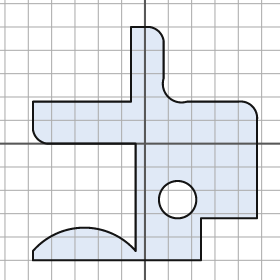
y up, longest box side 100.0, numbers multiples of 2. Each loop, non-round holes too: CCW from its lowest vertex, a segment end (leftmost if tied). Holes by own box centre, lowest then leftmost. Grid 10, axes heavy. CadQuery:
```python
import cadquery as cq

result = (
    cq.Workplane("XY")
    .moveTo(-48.0, -50.0)
    .lineTo(24.0, -50.0)
    .lineTo(24.0, -32.0)
    .lineTo(48.0, -32.0)
    .lineTo(48.0, 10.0)
    .threePointArc((46.0, 16.0), (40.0, 18.0))
    .lineTo(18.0, 18.0)
    .threePointArc((10.0, 20.0), (8.0, 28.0))
    .lineTo(8.0, 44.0)
    .threePointArc((6.0, 48.0), (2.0, 50.0))
    .lineTo(-6.0, 50.0)
    .lineTo(-6.0, 18.0)
    .lineTo(-48.0, 18.0)
    .lineTo(-48.0, 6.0)
    .threePointArc((-46.0, 2.0), (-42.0, 0.0))
    .lineTo(-4.0, 0.0)
    .lineTo(-4.0, -46.0)
    .threePointArc((-26.0, -36.0), (-48.0, -46.0))
    .close()
    .moveTo(14.0, -24.0)
    .circle(8.0)
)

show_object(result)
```